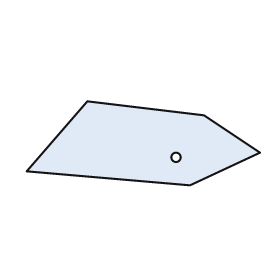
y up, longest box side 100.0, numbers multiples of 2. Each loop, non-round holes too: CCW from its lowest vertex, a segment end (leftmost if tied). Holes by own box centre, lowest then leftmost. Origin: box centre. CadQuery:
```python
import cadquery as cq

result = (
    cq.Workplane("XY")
    .moveTo(20.0, -18.0)
    .lineTo(50.0, -4.0)
    .lineTo(26.0, 12.0)
    .lineTo(-24.0, 18.0)
    .lineTo(-50.0, -12.0)
    .close()
    .moveTo(14.0, -6.0)
    .circle(2.0)
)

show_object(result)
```